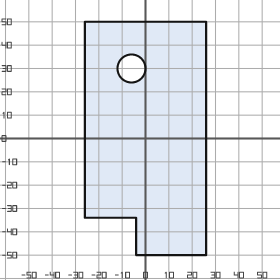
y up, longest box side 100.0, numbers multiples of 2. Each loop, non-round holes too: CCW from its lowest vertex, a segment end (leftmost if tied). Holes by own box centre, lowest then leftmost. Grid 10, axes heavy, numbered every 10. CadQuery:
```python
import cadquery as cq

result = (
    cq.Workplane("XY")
    .moveTo(-4.0, -50.0)
    .lineTo(26.0, -50.0)
    .lineTo(26.0, 50.0)
    .lineTo(-26.0, 50.0)
    .lineTo(-26.0, -34.0)
    .lineTo(-4.0, -34.0)
    .close()
    .moveTo(-6.0, 30.0)
    .circle(6.0)
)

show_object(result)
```